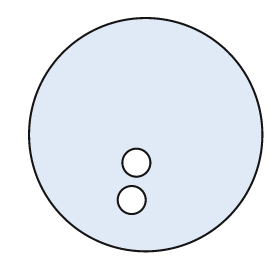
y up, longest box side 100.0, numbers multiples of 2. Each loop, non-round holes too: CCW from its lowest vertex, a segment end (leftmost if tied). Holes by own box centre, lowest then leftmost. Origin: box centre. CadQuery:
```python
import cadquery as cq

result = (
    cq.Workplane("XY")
    .moveTo(0.0, 0.0)
    .circle(50.0)
    .moveTo(-6.0, -28.0)
    .circle(6.0)
    .moveTo(-4.0, -12.0)
    .circle(6.0)
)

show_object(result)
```